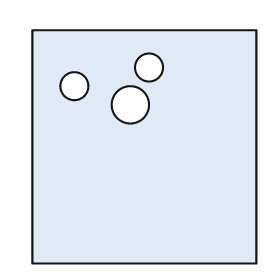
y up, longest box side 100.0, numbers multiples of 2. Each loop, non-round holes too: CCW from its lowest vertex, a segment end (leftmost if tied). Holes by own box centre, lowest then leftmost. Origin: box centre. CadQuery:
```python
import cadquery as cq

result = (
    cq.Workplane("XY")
    .moveTo(-48.0, -50.0)
    .lineTo(48.0, -50.0)
    .lineTo(48.0, 50.0)
    .lineTo(-48.0, 50.0)
    .close()
    .moveTo(-6.0, 18.0)
    .circle(8.0)
    .moveTo(-30.0, 26.0)
    .circle(6.0)
    .moveTo(2.0, 34.0)
    .circle(6.0)
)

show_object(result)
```